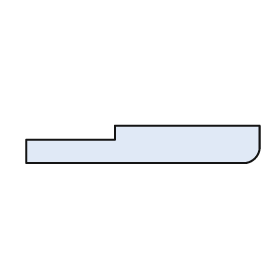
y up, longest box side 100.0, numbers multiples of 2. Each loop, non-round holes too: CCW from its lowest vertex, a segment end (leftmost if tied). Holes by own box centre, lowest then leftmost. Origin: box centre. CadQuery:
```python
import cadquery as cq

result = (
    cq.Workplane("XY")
    .moveTo(-50.0, -8.0)
    .lineTo(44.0, -8.0)
    .threePointArc((48.0, -6.0), (50.0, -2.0))
    .lineTo(50.0, 8.0)
    .lineTo(-12.0, 8.0)
    .lineTo(-12.0, 2.0)
    .lineTo(-50.0, 2.0)
    .close()
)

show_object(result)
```